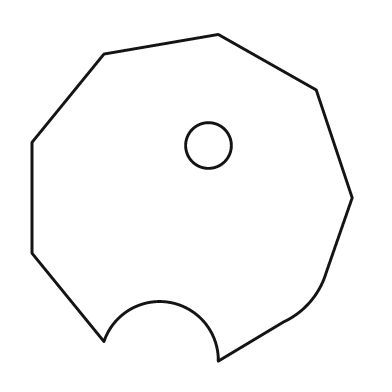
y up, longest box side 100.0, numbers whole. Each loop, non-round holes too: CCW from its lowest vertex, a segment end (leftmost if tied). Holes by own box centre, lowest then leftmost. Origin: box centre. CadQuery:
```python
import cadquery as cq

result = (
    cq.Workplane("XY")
    .moveTo(8.0, -50.0)
    .lineTo(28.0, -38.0)
    .threePointArc((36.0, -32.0), (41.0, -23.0))
    .lineTo(49.0, 0.0)
    .lineTo(38.0, 33.0)
    .lineTo(8.0, 50.0)
    .lineTo(-27.0, 44.0)
    .lineTo(-49.0, 17.0)
    .lineTo(-49.0, -17.0)
    .lineTo(-27.0, -44.0)
    .threePointArc((-7.0, -32.0), (8.0, -50.0))
    .close()
    .moveTo(5.0, 16.0)
    .circle(7.0)
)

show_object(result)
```